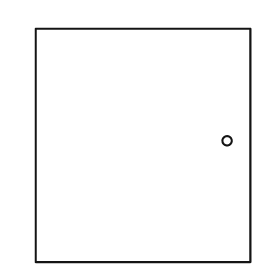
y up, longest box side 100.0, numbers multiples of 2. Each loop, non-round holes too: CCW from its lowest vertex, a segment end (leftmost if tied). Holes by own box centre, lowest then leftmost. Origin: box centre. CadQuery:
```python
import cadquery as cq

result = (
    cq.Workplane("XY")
    .moveTo(-46.0, -50.0)
    .lineTo(46.0, -50.0)
    .lineTo(46.0, 50.0)
    .lineTo(-46.0, 50.0)
    .close()
    .moveTo(36.0, 2.0)
    .circle(2.0)
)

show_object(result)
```